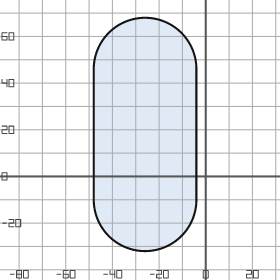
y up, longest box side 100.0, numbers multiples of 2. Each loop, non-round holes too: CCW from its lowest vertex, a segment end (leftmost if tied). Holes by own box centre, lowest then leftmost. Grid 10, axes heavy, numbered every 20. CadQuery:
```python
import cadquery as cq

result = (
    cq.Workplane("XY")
    .moveTo(-48.0, -10.0)
    .threePointArc((-26.0, -32.0), (-4.0, -10.0))
    .lineTo(-4.0, 46.0)
    .threePointArc((-26.0, 68.0), (-48.0, 46.0))
    .close()
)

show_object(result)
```